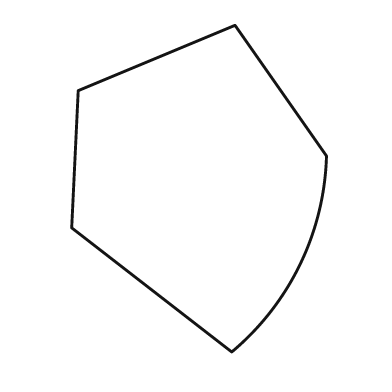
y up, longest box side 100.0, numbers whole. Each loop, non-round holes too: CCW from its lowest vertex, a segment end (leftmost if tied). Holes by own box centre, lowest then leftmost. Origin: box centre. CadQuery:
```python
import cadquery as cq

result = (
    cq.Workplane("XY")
    .moveTo(10.0, -50.0)
    .threePointArc((31.0, -23.0), (39.0, 10.0))
    .lineTo(11.0, 50.0)
    .lineTo(-37.0, 30.0)
    .lineTo(-39.0, -12.0)
    .close()
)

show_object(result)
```